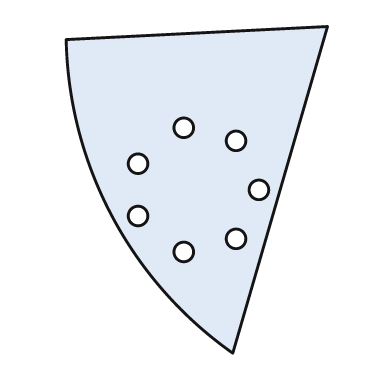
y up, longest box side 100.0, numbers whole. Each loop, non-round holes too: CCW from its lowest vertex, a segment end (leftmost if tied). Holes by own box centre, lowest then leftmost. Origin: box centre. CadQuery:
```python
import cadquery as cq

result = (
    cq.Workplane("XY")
    .moveTo(11.0, -50.0)
    .lineTo(40.0, 50.0)
    .lineTo(-40.0, 46.0)
    .threePointArc((-26.0, -8.0), (11.0, -50.0))
    .close()
    .moveTo(-4.0, -19.0)
    .circle(3.0)
    .moveTo(12.0, -15.0)
    .circle(3.0)
    .moveTo(-18.0, -8.0)
    .circle(3.0)
    .moveTo(19.0, 0.0)
    .circle(3.0)
    .moveTo(-18.0, 8.0)
    .circle(3.0)
    .moveTo(12.0, 15.0)
    .circle(3.0)
    .moveTo(-4.0, 19.0)
    .circle(3.0)
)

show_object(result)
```